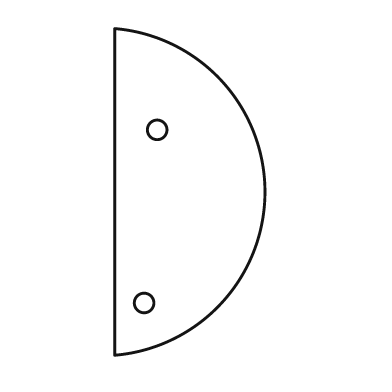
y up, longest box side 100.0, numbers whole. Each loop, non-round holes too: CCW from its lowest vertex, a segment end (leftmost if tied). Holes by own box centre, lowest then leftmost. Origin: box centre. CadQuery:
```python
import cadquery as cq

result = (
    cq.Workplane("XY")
    .moveTo(-23.0, -50.0)
    .threePointArc((23.0, 0.0), (-23.0, 50.0))
    .close()
    .moveTo(-14.0, -34.0)
    .circle(3.0)
    .moveTo(-10.0, 19.0)
    .circle(3.0)
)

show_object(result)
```